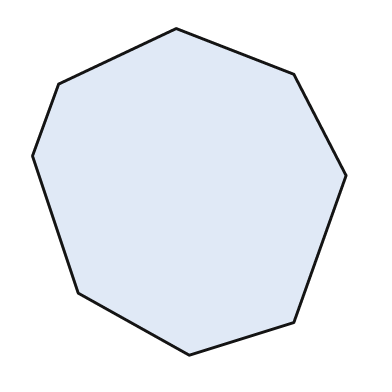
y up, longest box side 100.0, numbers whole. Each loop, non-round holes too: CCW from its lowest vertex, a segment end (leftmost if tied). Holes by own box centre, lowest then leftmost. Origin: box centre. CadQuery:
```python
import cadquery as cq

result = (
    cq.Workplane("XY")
    .moveTo(0.0, -50.0)
    .lineTo(32.0, -40.0)
    .lineTo(48.0, 5.0)
    .lineTo(32.0, 36.0)
    .lineTo(-4.0, 50.0)
    .lineTo(-40.0, 33.0)
    .lineTo(-48.0, 11.0)
    .lineTo(-34.0, -31.0)
    .close()
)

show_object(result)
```